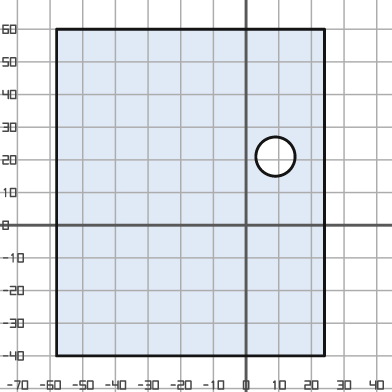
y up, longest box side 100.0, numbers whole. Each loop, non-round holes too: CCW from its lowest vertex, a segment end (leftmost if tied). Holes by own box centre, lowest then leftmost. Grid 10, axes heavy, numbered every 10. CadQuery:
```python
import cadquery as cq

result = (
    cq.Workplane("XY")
    .moveTo(-58.0, -40.0)
    .lineTo(24.0, -40.0)
    .lineTo(24.0, 60.0)
    .lineTo(-58.0, 60.0)
    .close()
    .moveTo(9.0, 21.0)
    .circle(6.0)
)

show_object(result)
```